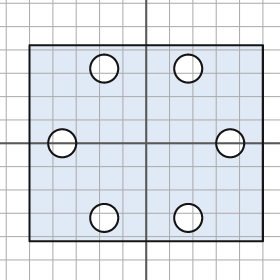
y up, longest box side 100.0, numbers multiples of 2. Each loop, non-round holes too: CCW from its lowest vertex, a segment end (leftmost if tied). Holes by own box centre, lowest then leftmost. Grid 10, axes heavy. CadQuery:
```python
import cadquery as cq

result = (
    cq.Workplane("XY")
    .moveTo(-50.0, -42.0)
    .lineTo(50.0, -42.0)
    .lineTo(50.0, 42.0)
    .lineTo(-50.0, 42.0)
    .close()
    .moveTo(-18.0, -32.0)
    .circle(6.0)
    .moveTo(18.0, -32.0)
    .circle(6.0)
    .moveTo(-36.0, 0.0)
    .circle(6.0)
    .moveTo(36.0, 0.0)
    .circle(6.0)
    .moveTo(-18.0, 32.0)
    .circle(6.0)
    .moveTo(18.0, 32.0)
    .circle(6.0)
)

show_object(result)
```